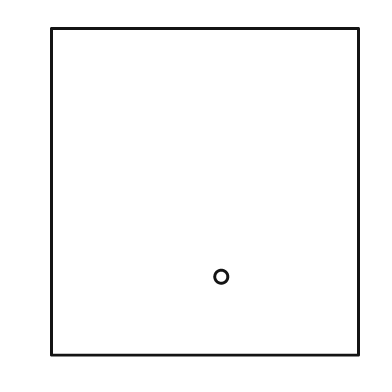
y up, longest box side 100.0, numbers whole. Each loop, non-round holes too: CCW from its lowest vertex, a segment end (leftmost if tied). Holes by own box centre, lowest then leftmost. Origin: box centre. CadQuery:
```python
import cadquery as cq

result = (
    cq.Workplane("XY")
    .moveTo(-47.0, -50.0)
    .lineTo(47.0, -50.0)
    .lineTo(47.0, 50.0)
    .lineTo(-47.0, 50.0)
    .close()
    .moveTo(5.0, -26.0)
    .circle(2.0)
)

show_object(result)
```